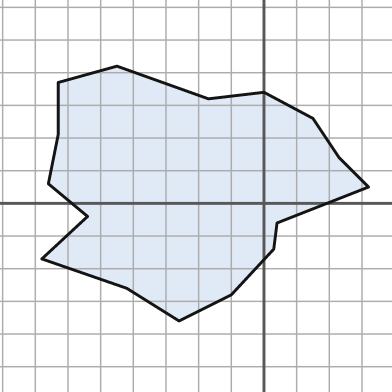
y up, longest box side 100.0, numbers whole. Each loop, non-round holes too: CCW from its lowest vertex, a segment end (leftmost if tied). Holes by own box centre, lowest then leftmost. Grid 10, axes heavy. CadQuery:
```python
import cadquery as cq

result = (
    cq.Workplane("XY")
    .moveTo(-26.0, -36.0)
    .lineTo(-10.0, -28.0)
    .lineTo(3.0, -14.0)
    .lineTo(4.0, -6.0)
    .lineTo(32.0, 5.0)
    .lineTo(23.0, 14.0)
    .lineTo(15.0, 26.0)
    .lineTo(0.0, 34.0)
    .lineTo(-17.0, 32.0)
    .lineTo(-45.0, 42.0)
    .lineTo(-63.0, 37.0)
    .lineTo(-63.0, 21.0)
    .lineTo(-66.0, 6.0)
    .lineTo(-54.0, -4.0)
    .lineTo(-68.0, -17.0)
    .lineTo(-42.0, -26.0)
    .close()
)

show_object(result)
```